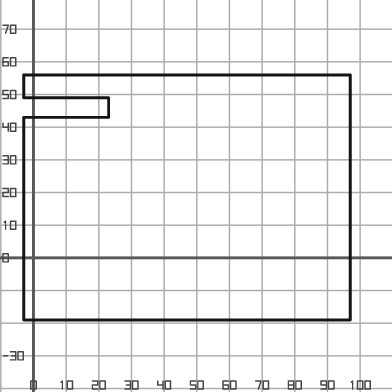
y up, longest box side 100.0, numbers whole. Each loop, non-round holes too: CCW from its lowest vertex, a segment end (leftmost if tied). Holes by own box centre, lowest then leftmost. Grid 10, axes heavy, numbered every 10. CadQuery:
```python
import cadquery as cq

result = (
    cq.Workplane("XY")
    .moveTo(-3.0, -19.0)
    .lineTo(97.0, -19.0)
    .lineTo(97.0, 56.0)
    .lineTo(-3.0, 56.0)
    .lineTo(-3.0, 49.0)
    .lineTo(23.0, 49.0)
    .lineTo(23.0, 43.0)
    .lineTo(-3.0, 43.0)
    .close()
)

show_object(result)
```